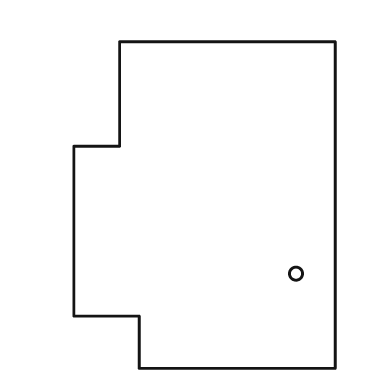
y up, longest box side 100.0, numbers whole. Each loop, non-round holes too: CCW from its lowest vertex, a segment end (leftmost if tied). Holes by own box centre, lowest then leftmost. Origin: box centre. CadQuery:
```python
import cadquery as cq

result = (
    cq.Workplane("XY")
    .moveTo(-20.0, -50.0)
    .lineTo(40.0, -50.0)
    .lineTo(40.0, 50.0)
    .lineTo(-26.0, 50.0)
    .lineTo(-26.0, 18.0)
    .lineTo(-40.0, 18.0)
    .lineTo(-40.0, -34.0)
    .lineTo(-20.0, -34.0)
    .close()
    .moveTo(28.0, -21.0)
    .circle(2.0)
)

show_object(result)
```